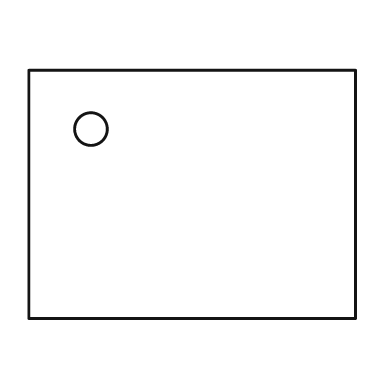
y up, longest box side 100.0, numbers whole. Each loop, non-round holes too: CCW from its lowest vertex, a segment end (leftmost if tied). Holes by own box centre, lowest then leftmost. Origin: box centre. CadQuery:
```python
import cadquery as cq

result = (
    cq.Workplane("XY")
    .moveTo(-50.0, -38.0)
    .lineTo(50.0, -38.0)
    .lineTo(50.0, 38.0)
    .lineTo(-50.0, 38.0)
    .close()
    .moveTo(-31.0, 20.0)
    .circle(5.0)
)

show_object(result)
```